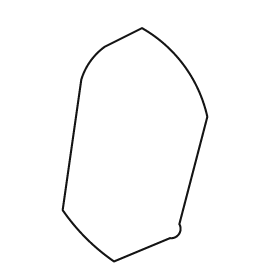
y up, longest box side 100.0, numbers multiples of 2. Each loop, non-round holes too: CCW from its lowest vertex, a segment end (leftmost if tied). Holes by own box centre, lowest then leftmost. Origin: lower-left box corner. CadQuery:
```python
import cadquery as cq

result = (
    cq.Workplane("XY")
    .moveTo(22.0, 0.0)
    .lineTo(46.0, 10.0)
    .threePointArc((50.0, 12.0), (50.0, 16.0))
    .lineTo(62.0, 62.0)
    .threePointArc((52.0, 84.0), (34.0, 100.0))
    .lineTo(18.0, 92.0)
    .threePointArc((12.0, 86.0), (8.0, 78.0))
    .lineTo(0.0, 22.0)
    .threePointArc((10.0, 10.0), (22.0, 0.0))
    .close()
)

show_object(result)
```